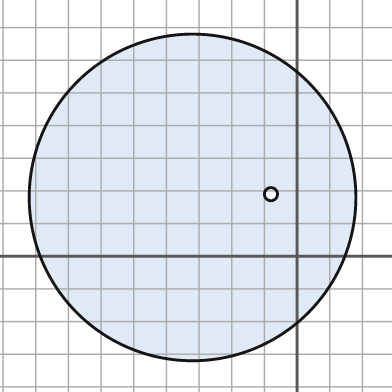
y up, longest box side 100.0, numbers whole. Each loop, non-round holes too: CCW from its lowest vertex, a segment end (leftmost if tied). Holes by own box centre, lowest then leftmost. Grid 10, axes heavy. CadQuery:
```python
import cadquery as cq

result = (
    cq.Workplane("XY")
    .moveTo(-32.0, 18.0)
    .circle(50.0)
    .moveTo(-8.0, 19.0)
    .circle(2.0)
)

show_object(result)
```